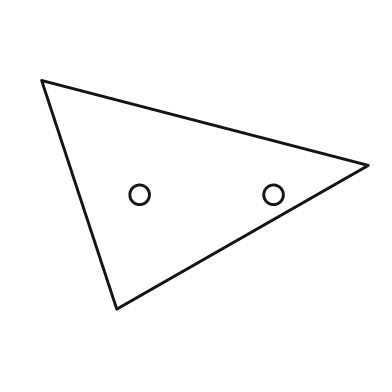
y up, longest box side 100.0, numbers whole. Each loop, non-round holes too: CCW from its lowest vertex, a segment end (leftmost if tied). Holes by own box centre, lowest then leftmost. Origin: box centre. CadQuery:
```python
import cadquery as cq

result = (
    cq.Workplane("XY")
    .moveTo(-27.0, -35.0)
    .lineTo(50.0, 9.0)
    .lineTo(-50.0, 35.0)
    .close()
    .moveTo(-20.0, 0.0)
    .circle(3.0)
    .moveTo(21.0, 0.0)
    .circle(3.0)
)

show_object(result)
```